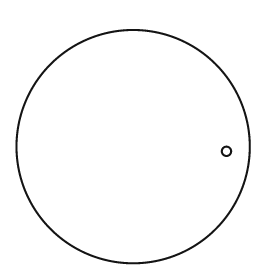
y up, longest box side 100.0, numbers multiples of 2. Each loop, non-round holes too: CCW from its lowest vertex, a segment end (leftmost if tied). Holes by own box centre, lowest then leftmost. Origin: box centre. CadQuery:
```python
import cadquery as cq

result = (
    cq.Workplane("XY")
    .moveTo(0.0, 0.0)
    .circle(50.0)
    .moveTo(40.0, -2.0)
    .circle(2.0)
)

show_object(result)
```